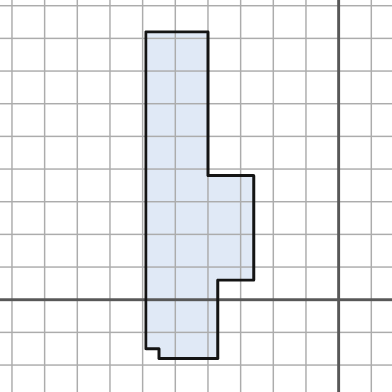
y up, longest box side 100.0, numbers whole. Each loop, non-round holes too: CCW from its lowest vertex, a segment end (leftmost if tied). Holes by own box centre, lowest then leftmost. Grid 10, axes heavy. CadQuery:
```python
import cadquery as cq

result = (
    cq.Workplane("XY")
    .moveTo(-55.0, -18.0)
    .lineTo(-37.0, -18.0)
    .lineTo(-37.0, 6.0)
    .lineTo(-26.0, 6.0)
    .lineTo(-26.0, 38.0)
    .lineTo(-40.0, 38.0)
    .lineTo(-40.0, 82.0)
    .lineTo(-59.0, 82.0)
    .lineTo(-59.0, -15.0)
    .lineTo(-55.0, -15.0)
    .close()
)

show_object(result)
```